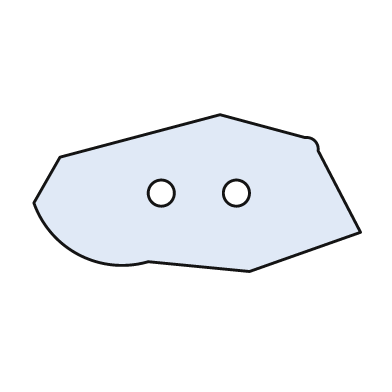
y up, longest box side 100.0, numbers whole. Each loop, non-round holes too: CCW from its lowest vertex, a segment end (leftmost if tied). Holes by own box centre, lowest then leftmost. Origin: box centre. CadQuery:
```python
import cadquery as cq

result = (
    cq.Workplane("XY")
    .moveTo(16.0, -24.0)
    .lineTo(50.0, -12.0)
    .lineTo(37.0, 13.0)
    .threePointArc((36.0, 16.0), (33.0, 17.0))
    .lineTo(7.0, 24.0)
    .lineTo(-42.0, 11.0)
    .lineTo(-50.0, -3.0)
    .threePointArc((-36.0, -19.0), (-15.0, -21.0))
    .close()
    .moveTo(-11.0, 0.0)
    .circle(4.0)
    .moveTo(12.0, 0.0)
    .circle(4.0)
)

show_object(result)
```